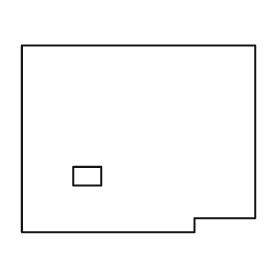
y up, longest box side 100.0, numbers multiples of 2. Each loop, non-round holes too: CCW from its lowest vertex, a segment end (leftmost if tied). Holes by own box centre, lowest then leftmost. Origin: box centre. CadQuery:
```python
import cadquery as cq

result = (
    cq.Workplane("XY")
    .moveTo(-50.0, -40.0)
    .lineTo(24.0, -40.0)
    .lineTo(24.0, -34.0)
    .lineTo(50.0, -34.0)
    .lineTo(50.0, 40.0)
    .lineTo(-50.0, 40.0)
    .close()
    .moveTo(-28.0, -20.0)
    .lineTo(-16.0, -20.0)
    .lineTo(-16.0, -12.0)
    .lineTo(-28.0, -12.0)
    .close()
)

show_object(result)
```